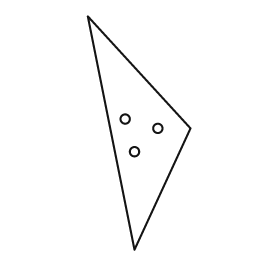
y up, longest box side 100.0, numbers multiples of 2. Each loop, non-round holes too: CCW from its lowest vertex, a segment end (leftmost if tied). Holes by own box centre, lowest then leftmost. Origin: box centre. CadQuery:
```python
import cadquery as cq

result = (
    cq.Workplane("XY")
    .moveTo(-2.0, -50.0)
    .lineTo(22.0, 2.0)
    .lineTo(-22.0, 50.0)
    .close()
    .moveTo(-2.0, -8.0)
    .circle(2.0)
    .moveTo(8.0, 2.0)
    .circle(2.0)
    .moveTo(-6.0, 6.0)
    .circle(2.0)
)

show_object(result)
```